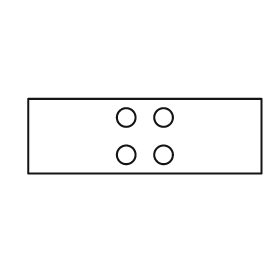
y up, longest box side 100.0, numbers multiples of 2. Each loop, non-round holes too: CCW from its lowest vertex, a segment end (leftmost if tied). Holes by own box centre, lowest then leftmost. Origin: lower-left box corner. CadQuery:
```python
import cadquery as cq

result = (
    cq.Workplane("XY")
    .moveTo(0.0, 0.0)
    .lineTo(100.0, 0.0)
    .lineTo(100.0, 32.0)
    .lineTo(0.0, 32.0)
    .close()
    .moveTo(42.0, 8.0)
    .circle(4.0)
    .moveTo(58.0, 8.0)
    .circle(4.0)
    .moveTo(42.0, 24.0)
    .circle(4.0)
    .moveTo(58.0, 24.0)
    .circle(4.0)
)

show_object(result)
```